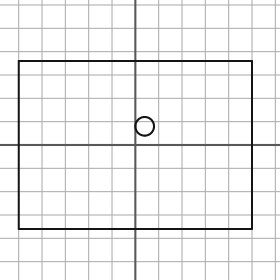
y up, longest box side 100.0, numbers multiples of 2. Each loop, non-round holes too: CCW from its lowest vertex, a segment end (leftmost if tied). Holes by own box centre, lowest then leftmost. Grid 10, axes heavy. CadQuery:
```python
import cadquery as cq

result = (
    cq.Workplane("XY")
    .moveTo(-50.0, -36.0)
    .lineTo(50.0, -36.0)
    .lineTo(50.0, 36.0)
    .lineTo(-50.0, 36.0)
    .close()
    .moveTo(4.0, 8.0)
    .circle(4.0)
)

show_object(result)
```